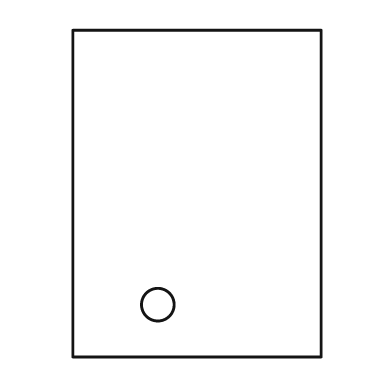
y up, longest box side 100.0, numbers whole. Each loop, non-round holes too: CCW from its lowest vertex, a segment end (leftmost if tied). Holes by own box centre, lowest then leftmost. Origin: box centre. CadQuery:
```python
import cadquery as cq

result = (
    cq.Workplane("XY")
    .moveTo(-38.0, -50.0)
    .lineTo(38.0, -50.0)
    .lineTo(38.0, 50.0)
    .lineTo(-38.0, 50.0)
    .close()
    .moveTo(-12.0, -34.0)
    .circle(5.0)
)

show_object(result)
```